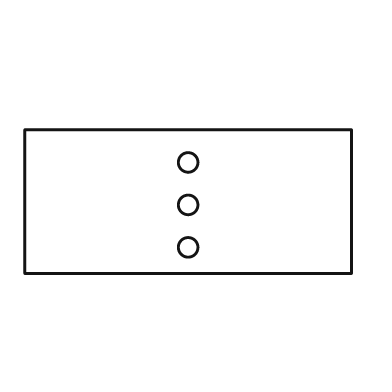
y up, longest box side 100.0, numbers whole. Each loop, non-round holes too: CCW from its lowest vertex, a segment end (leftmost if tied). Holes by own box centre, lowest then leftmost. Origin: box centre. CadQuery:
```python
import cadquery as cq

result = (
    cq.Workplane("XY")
    .moveTo(-50.0, -22.0)
    .lineTo(50.0, -22.0)
    .lineTo(50.0, 22.0)
    .lineTo(-50.0, 22.0)
    .close()
    .moveTo(0.0, -14.0)
    .circle(3.0)
    .moveTo(0.0, -1.0)
    .circle(3.0)
    .moveTo(0.0, 12.0)
    .circle(3.0)
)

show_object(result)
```